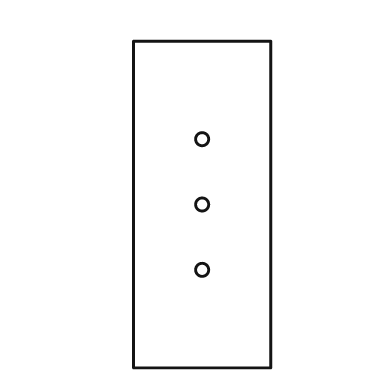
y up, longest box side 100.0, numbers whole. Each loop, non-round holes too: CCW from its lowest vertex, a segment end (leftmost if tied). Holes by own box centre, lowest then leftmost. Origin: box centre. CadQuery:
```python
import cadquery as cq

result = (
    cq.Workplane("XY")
    .moveTo(-21.0, -50.0)
    .lineTo(21.0, -50.0)
    .lineTo(21.0, 50.0)
    .lineTo(-21.0, 50.0)
    .close()
    .moveTo(0.0, -20.0)
    .circle(2.0)
    .moveTo(0.0, 0.0)
    .circle(2.0)
    .moveTo(0.0, 20.0)
    .circle(2.0)
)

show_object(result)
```